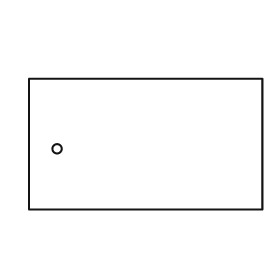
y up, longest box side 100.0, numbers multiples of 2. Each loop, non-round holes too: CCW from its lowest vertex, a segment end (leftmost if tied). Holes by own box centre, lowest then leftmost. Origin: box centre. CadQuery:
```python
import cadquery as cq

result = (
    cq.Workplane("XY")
    .moveTo(-50.0, -28.0)
    .lineTo(50.0, -28.0)
    .lineTo(50.0, 28.0)
    .lineTo(-50.0, 28.0)
    .close()
    .moveTo(-38.0, -2.0)
    .circle(2.0)
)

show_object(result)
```